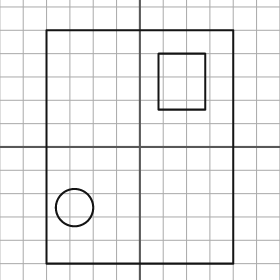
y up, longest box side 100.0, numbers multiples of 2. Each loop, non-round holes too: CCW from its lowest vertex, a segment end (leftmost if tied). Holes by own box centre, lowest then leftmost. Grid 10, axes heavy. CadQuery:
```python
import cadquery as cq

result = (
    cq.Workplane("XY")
    .moveTo(-40.0, -50.0)
    .lineTo(40.0, -50.0)
    .lineTo(40.0, 50.0)
    .lineTo(-40.0, 50.0)
    .close()
    .moveTo(-28.0, -26.0)
    .circle(8.0)
    .moveTo(8.0, 16.0)
    .lineTo(28.0, 16.0)
    .lineTo(28.0, 40.0)
    .lineTo(8.0, 40.0)
    .close()
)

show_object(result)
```